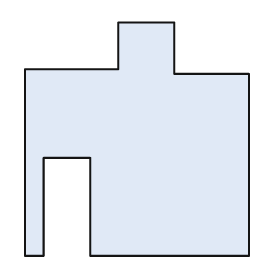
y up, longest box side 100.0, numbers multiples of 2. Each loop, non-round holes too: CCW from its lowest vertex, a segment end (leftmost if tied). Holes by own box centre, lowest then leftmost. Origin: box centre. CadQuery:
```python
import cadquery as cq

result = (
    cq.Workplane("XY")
    .moveTo(-48.0, -50.0)
    .lineTo(-40.0, -50.0)
    .lineTo(-40.0, -8.0)
    .lineTo(-20.0, -8.0)
    .lineTo(-20.0, -50.0)
    .lineTo(48.0, -50.0)
    .lineTo(48.0, 28.0)
    .lineTo(16.0, 28.0)
    .lineTo(16.0, 50.0)
    .lineTo(-8.0, 50.0)
    .lineTo(-8.0, 30.0)
    .lineTo(-48.0, 30.0)
    .close()
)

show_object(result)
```